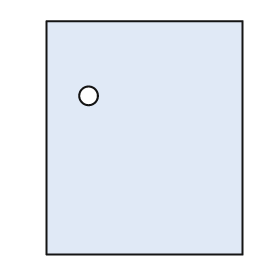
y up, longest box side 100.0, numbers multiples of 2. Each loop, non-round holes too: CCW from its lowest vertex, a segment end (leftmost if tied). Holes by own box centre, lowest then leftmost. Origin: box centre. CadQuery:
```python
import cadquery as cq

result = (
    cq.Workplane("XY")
    .moveTo(-42.0, -50.0)
    .lineTo(42.0, -50.0)
    .lineTo(42.0, 50.0)
    .lineTo(-42.0, 50.0)
    .close()
    .moveTo(-24.0, 18.0)
    .circle(4.0)
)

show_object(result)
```